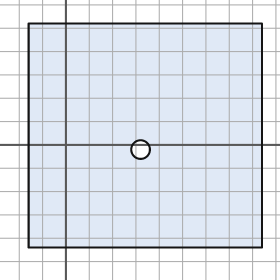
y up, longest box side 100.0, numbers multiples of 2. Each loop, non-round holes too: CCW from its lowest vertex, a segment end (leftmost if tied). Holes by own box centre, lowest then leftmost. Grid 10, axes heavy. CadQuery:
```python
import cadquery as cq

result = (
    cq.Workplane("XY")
    .moveTo(-16.0, -44.0)
    .lineTo(84.0, -44.0)
    .lineTo(84.0, 52.0)
    .lineTo(-16.0, 52.0)
    .close()
    .moveTo(32.0, -2.0)
    .circle(4.0)
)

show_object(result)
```